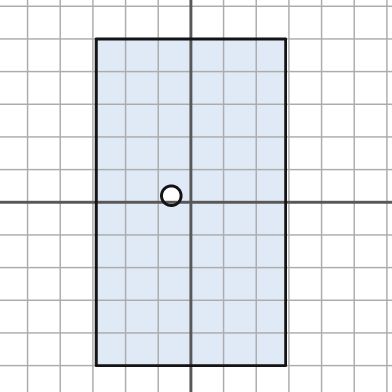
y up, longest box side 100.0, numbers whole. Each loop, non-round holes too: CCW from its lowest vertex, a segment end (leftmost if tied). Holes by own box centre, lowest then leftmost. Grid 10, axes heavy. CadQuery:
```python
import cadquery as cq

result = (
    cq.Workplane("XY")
    .moveTo(-29.0, -50.0)
    .lineTo(29.0, -50.0)
    .lineTo(29.0, 50.0)
    .lineTo(-29.0, 50.0)
    .close()
    .moveTo(-6.0, 2.0)
    .circle(3.0)
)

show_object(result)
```